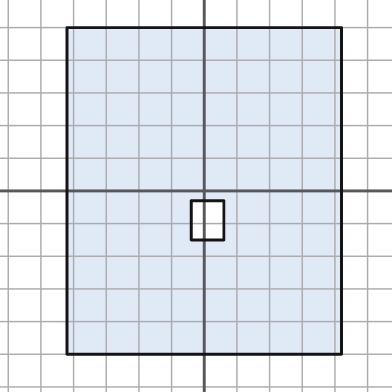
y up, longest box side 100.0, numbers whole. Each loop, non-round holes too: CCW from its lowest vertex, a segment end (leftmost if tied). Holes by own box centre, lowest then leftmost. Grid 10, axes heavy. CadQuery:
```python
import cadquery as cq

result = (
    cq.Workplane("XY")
    .moveTo(-42.0, -50.0)
    .lineTo(42.0, -50.0)
    .lineTo(42.0, 50.0)
    .lineTo(-42.0, 50.0)
    .close()
    .moveTo(-4.0, -15.0)
    .lineTo(6.0, -15.0)
    .lineTo(6.0, -3.0)
    .lineTo(-4.0, -3.0)
    .close()
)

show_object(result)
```